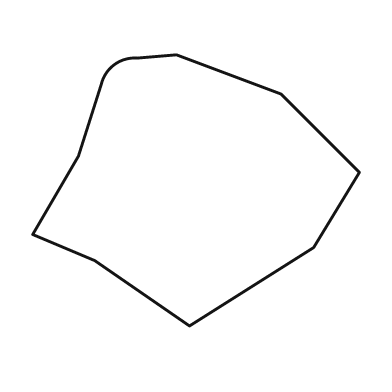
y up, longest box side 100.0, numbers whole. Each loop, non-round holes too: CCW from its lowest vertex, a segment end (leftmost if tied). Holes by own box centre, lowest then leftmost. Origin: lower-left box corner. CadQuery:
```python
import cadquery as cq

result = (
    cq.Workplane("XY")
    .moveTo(48.0, 0.0)
    .lineTo(86.0, 24.0)
    .lineTo(100.0, 47.0)
    .lineTo(76.0, 71.0)
    .lineTo(44.0, 83.0)
    .lineTo(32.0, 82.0)
    .threePointArc((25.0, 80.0), (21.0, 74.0))
    .lineTo(14.0, 52.0)
    .lineTo(0.0, 28.0)
    .lineTo(19.0, 20.0)
    .close()
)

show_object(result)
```